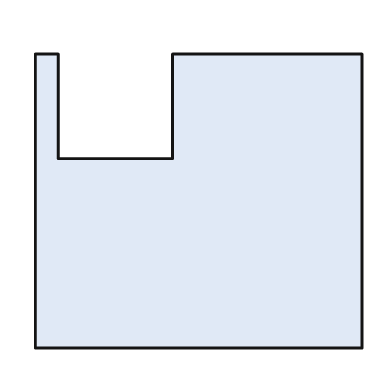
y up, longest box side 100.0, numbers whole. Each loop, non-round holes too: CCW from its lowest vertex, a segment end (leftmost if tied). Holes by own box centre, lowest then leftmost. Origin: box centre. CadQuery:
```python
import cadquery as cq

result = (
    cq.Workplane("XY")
    .moveTo(-50.0, -45.0)
    .lineTo(50.0, -45.0)
    .lineTo(50.0, 45.0)
    .lineTo(-8.0, 45.0)
    .lineTo(-8.0, 13.0)
    .lineTo(-43.0, 13.0)
    .lineTo(-43.0, 45.0)
    .lineTo(-50.0, 45.0)
    .close()
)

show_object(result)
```